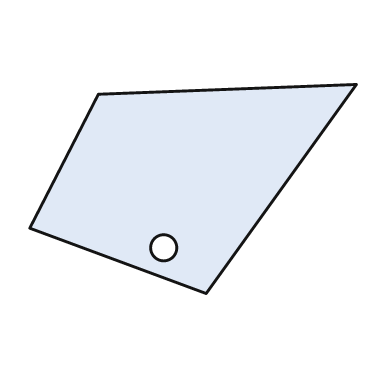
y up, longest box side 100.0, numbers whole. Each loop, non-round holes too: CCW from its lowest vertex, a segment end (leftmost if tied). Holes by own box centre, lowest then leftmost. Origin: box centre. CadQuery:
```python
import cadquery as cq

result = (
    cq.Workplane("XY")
    .moveTo(4.0, -32.0)
    .lineTo(50.0, 32.0)
    .lineTo(-29.0, 29.0)
    .lineTo(-50.0, -12.0)
    .close()
    .moveTo(-9.0, -18.0)
    .circle(4.0)
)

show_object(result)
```